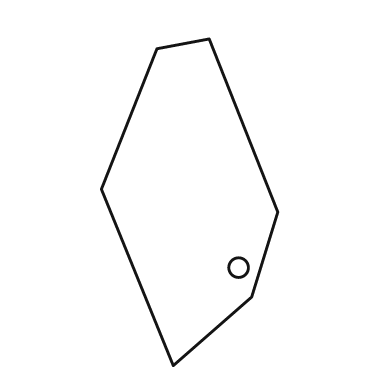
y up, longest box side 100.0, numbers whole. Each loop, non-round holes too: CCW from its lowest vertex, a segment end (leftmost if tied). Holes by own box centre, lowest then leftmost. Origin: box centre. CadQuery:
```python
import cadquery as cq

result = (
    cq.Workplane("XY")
    .moveTo(-5.0, -50.0)
    .lineTo(19.0, -29.0)
    .lineTo(27.0, -3.0)
    .lineTo(6.0, 50.0)
    .lineTo(-10.0, 47.0)
    .lineTo(-27.0, 4.0)
    .close()
    .moveTo(15.0, -20.0)
    .circle(3.0)
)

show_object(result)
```